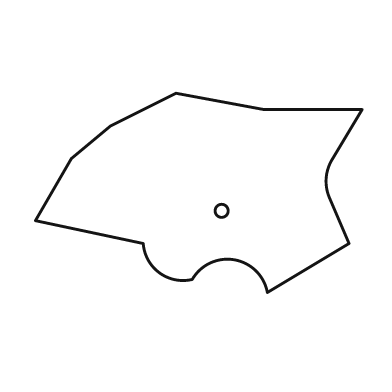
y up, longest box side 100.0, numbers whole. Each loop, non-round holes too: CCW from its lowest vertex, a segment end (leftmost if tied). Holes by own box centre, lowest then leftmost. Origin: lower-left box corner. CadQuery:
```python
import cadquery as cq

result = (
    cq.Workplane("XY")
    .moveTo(71.0, 0.0)
    .lineTo(96.0, 15.0)
    .lineTo(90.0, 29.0)
    .threePointArc((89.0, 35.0), (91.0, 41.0))
    .lineTo(100.0, 56.0)
    .lineTo(70.0, 56.0)
    .lineTo(43.0, 61.0)
    .lineTo(23.0, 51.0)
    .lineTo(11.0, 41.0)
    .lineTo(0.0, 22.0)
    .lineTo(33.0, 15.0)
    .threePointArc((38.0, 6.0), (48.0, 4.0))
    .threePointArc((61.0, 10.0), (71.0, 0.0))
    .close()
    .moveTo(57.0, 25.0)
    .circle(2.0)
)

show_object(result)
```